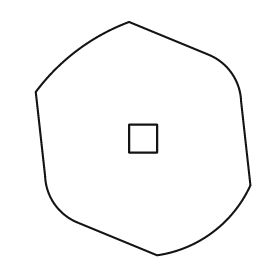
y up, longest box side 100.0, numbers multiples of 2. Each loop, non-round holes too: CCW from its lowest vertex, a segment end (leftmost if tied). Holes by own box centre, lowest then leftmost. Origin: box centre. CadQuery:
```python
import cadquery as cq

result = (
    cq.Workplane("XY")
    .moveTo(6.0, -50.0)
    .threePointArc((30.0, -40.0), (46.0, -20.0))
    .lineTo(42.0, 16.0)
    .threePointArc((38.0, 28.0), (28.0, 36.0))
    .lineTo(-6.0, 50.0)
    .threePointArc((-28.0, 38.0), (-46.0, 20.0))
    .lineTo(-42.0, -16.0)
    .threePointArc((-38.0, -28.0), (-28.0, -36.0))
    .close()
    .moveTo(-6.0, -6.0)
    .lineTo(6.0, -6.0)
    .lineTo(6.0, 6.0)
    .lineTo(-6.0, 6.0)
    .close()
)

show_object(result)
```